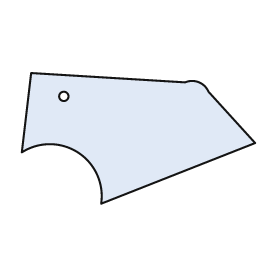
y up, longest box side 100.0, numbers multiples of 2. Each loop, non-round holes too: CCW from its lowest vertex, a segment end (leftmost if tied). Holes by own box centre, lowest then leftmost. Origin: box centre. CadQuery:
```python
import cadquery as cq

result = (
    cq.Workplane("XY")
    .moveTo(-16.0, -28.0)
    .lineTo(50.0, -2.0)
    .lineTo(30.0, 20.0)
    .threePointArc((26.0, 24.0), (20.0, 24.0))
    .lineTo(-46.0, 28.0)
    .lineTo(-50.0, -6.0)
    .threePointArc((-26.0, -6.0), (-16.0, -28.0))
    .close()
    .moveTo(-32.0, 18.0)
    .circle(2.0)
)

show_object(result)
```